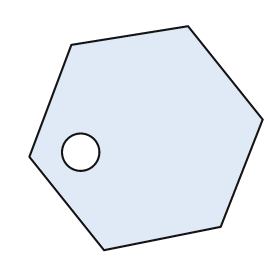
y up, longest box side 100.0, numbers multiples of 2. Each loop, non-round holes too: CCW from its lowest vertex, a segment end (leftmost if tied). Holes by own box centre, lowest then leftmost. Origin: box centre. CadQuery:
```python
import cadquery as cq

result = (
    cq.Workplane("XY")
    .moveTo(-18.0, -48.0)
    .lineTo(32.0, -38.0)
    .lineTo(50.0, 8.0)
    .lineTo(18.0, 48.0)
    .lineTo(-32.0, 40.0)
    .lineTo(-50.0, -8.0)
    .close()
    .moveTo(-28.0, -6.0)
    .circle(8.0)
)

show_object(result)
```